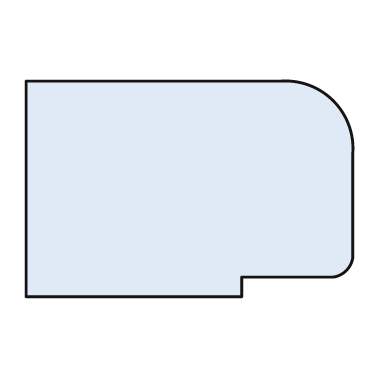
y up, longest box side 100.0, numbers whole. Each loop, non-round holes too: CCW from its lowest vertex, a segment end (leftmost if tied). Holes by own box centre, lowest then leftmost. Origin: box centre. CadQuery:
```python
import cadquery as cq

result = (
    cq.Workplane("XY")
    .moveTo(-50.0, -33.0)
    .lineTo(16.0, -33.0)
    .lineTo(16.0, -27.0)
    .lineTo(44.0, -27.0)
    .threePointArc((48.0, -25.0), (50.0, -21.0))
    .lineTo(50.0, 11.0)
    .threePointArc((44.0, 27.0), (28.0, 33.0))
    .lineTo(-50.0, 33.0)
    .close()
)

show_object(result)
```